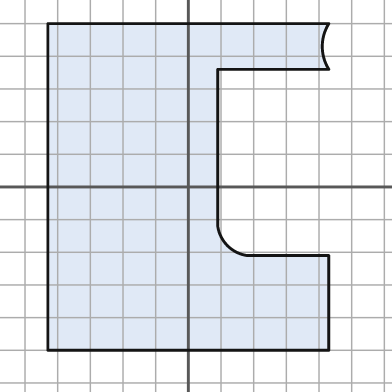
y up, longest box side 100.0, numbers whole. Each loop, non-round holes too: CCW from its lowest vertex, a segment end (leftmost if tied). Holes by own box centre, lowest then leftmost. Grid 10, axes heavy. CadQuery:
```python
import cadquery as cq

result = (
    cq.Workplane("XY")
    .moveTo(-43.0, -50.0)
    .lineTo(43.0, -50.0)
    .lineTo(43.0, -21.0)
    .lineTo(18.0, -21.0)
    .threePointArc((12.0, -18.0), (9.0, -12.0))
    .lineTo(9.0, 36.0)
    .lineTo(43.0, 36.0)
    .threePointArc((41.0, 43.0), (43.0, 50.0))
    .lineTo(-43.0, 50.0)
    .close()
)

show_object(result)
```